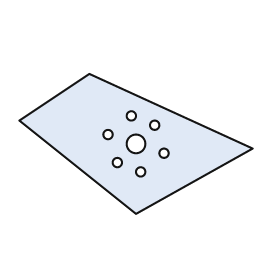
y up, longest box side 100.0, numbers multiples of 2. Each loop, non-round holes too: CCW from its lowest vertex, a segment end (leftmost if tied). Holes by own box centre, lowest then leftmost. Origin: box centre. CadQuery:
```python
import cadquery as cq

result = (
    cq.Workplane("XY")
    .moveTo(0.0, -30.0)
    .lineTo(50.0, -2.0)
    .lineTo(-20.0, 30.0)
    .lineTo(-50.0, 10.0)
    .close()
    .moveTo(2.0, -12.0)
    .circle(2.0)
    .moveTo(-8.0, -8.0)
    .circle(2.0)
    .moveTo(12.0, -4.0)
    .circle(2.0)
    .moveTo(0.0, 0.0)
    .circle(4.0)
    .moveTo(-12.0, 4.0)
    .circle(2.0)
    .moveTo(8.0, 8.0)
    .circle(2.0)
    .moveTo(-2.0, 12.0)
    .circle(2.0)
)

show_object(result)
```